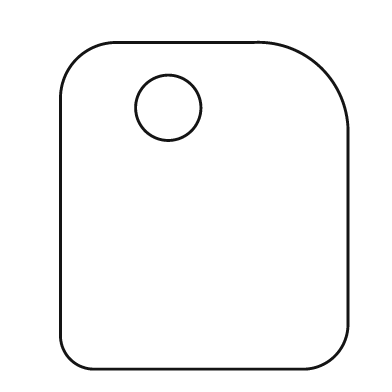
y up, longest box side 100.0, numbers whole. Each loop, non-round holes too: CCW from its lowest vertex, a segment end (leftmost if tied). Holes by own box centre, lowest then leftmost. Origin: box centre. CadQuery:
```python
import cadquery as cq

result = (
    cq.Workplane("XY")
    .moveTo(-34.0, -50.0)
    .lineTo(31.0, -50.0)
    .threePointArc((40.0, -46.0), (44.0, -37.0))
    .lineTo(44.0, 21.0)
    .threePointArc((36.0, 42.0), (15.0, 50.0))
    .lineTo(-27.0, 50.0)
    .threePointArc((-39.0, 45.0), (-44.0, 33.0))
    .lineTo(-44.0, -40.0)
    .threePointArc((-41.0, -47.0), (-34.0, -50.0))
    .close()
    .moveTo(-11.0, 30.0)
    .circle(10.0)
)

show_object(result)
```